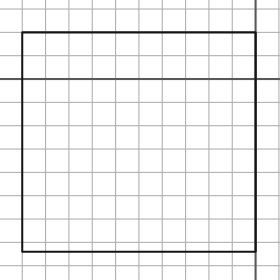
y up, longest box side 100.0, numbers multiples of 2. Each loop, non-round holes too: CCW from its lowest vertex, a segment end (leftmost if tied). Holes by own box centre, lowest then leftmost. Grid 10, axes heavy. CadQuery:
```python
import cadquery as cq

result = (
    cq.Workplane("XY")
    .moveTo(-100.0, -74.0)
    .lineTo(0.0, -74.0)
    .lineTo(0.0, 20.0)
    .lineTo(-100.0, 20.0)
    .close()
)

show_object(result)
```